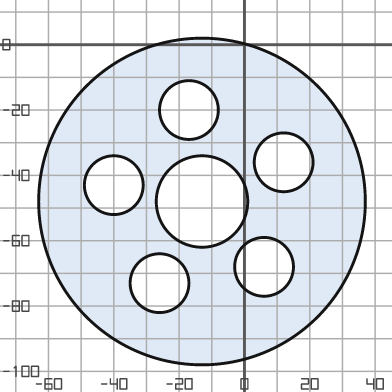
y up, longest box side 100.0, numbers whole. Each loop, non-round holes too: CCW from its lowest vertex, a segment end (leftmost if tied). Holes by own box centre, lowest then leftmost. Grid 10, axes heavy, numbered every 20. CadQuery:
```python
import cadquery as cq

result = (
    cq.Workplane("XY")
    .moveTo(-13.0, -48.0)
    .circle(50.0)
    .moveTo(-26.0, -73.0)
    .circle(9.0)
    .moveTo(6.0, -68.0)
    .circle(9.0)
    .moveTo(-13.0, -48.0)
    .circle(14.0)
    .moveTo(-40.0, -43.0)
    .circle(9.0)
    .moveTo(12.0, -36.0)
    .circle(9.0)
    .moveTo(-17.0, -20.0)
    .circle(9.0)
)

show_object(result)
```